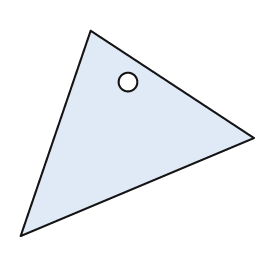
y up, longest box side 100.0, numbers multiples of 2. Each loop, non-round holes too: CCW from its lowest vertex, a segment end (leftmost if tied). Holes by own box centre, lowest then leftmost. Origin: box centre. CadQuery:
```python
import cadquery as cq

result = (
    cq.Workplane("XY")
    .moveTo(-50.0, -44.0)
    .lineTo(50.0, -2.0)
    .lineTo(-20.0, 44.0)
    .close()
    .moveTo(-4.0, 22.0)
    .circle(4.0)
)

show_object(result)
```